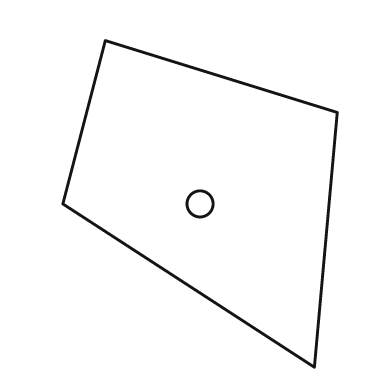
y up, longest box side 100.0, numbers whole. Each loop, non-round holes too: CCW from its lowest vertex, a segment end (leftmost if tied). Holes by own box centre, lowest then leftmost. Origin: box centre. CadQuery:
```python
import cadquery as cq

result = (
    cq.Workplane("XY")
    .moveTo(35.0, -50.0)
    .lineTo(42.0, 28.0)
    .lineTo(-29.0, 50.0)
    .lineTo(-42.0, 0.0)
    .close()
    .moveTo(0.0, 0.0)
    .circle(4.0)
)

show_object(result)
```